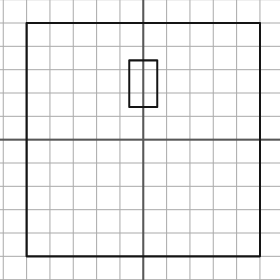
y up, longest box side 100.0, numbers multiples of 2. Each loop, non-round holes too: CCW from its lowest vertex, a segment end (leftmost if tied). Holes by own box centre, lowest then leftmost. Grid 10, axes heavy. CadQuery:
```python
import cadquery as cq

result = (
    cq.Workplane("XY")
    .moveTo(-50.0, -50.0)
    .lineTo(50.0, -50.0)
    .lineTo(50.0, 50.0)
    .lineTo(-50.0, 50.0)
    .close()
    .moveTo(-6.0, 14.0)
    .lineTo(6.0, 14.0)
    .lineTo(6.0, 34.0)
    .lineTo(-6.0, 34.0)
    .close()
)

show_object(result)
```